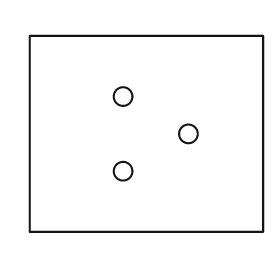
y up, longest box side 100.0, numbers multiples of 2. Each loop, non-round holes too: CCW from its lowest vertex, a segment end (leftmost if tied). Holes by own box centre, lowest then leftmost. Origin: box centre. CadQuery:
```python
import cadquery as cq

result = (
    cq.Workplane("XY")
    .moveTo(-50.0, -42.0)
    .lineTo(50.0, -42.0)
    .lineTo(50.0, 42.0)
    .lineTo(-50.0, 42.0)
    .close()
    .moveTo(-10.0, -16.0)
    .circle(4.0)
    .moveTo(18.0, 0.0)
    .circle(4.0)
    .moveTo(-10.0, 16.0)
    .circle(4.0)
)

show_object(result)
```